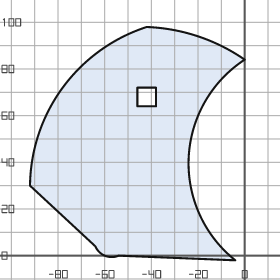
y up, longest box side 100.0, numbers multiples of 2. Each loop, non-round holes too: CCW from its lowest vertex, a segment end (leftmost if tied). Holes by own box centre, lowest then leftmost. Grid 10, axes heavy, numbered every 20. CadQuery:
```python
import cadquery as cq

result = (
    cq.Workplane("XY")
    .moveTo(-4.0, -2.0)
    .threePointArc((-24.0, 42.0), (0.0, 84.0))
    .threePointArc((-20.0, 94.0), (-42.0, 98.0))
    .threePointArc((-78.0, 72.0), (-92.0, 30.0))
    .lineTo(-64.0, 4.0)
    .threePointArc((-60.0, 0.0), (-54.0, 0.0))
    .close()
    .moveTo(-46.0, 64.0)
    .lineTo(-38.0, 64.0)
    .lineTo(-38.0, 72.0)
    .lineTo(-46.0, 72.0)
    .close()
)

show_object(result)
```